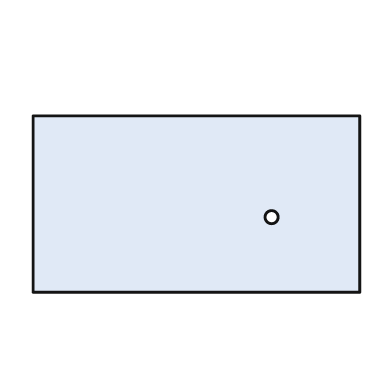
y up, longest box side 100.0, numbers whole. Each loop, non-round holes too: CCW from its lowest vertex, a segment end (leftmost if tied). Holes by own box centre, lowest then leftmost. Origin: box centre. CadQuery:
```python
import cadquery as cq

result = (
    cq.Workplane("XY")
    .moveTo(-50.0, -27.0)
    .lineTo(50.0, -27.0)
    .lineTo(50.0, 27.0)
    .lineTo(-50.0, 27.0)
    .close()
    .moveTo(23.0, -4.0)
    .circle(2.0)
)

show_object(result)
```